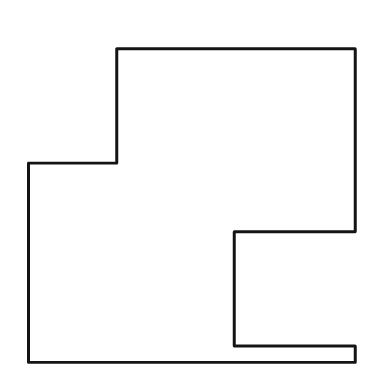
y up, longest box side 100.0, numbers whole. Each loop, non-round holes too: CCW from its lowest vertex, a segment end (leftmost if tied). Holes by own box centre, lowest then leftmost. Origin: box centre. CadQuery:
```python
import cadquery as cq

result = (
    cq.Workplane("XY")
    .moveTo(-50.0, -48.0)
    .lineTo(50.0, -48.0)
    .lineTo(50.0, -43.0)
    .lineTo(13.0, -43.0)
    .lineTo(13.0, -8.0)
    .lineTo(50.0, -8.0)
    .lineTo(50.0, 48.0)
    .lineTo(-23.0, 48.0)
    .lineTo(-23.0, 13.0)
    .lineTo(-50.0, 13.0)
    .close()
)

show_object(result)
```